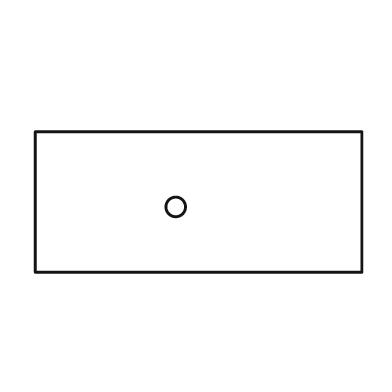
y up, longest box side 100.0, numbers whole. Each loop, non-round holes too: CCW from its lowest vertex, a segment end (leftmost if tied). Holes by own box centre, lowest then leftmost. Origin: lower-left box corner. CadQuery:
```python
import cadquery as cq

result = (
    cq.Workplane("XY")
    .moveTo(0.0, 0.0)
    .lineTo(100.0, 0.0)
    .lineTo(100.0, 43.0)
    .lineTo(0.0, 43.0)
    .close()
    .moveTo(43.0, 20.0)
    .circle(3.0)
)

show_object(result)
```